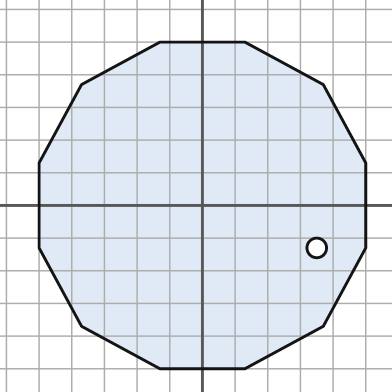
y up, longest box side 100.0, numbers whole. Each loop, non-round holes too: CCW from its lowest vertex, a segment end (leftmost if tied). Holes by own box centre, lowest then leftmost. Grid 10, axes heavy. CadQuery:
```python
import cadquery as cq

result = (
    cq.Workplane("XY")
    .moveTo(-13.0, -50.0)
    .lineTo(13.0, -50.0)
    .lineTo(37.0, -37.0)
    .lineTo(50.0, -13.0)
    .lineTo(50.0, 13.0)
    .lineTo(37.0, 37.0)
    .lineTo(13.0, 50.0)
    .lineTo(-13.0, 50.0)
    .lineTo(-37.0, 37.0)
    .lineTo(-50.0, 13.0)
    .lineTo(-50.0, -13.0)
    .lineTo(-37.0, -37.0)
    .close()
    .moveTo(35.0, -13.0)
    .circle(3.0)
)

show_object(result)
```